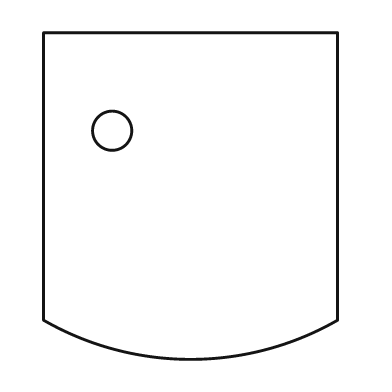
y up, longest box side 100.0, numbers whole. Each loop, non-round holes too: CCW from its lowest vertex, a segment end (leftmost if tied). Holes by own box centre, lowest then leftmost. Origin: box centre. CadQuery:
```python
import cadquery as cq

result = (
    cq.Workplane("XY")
    .moveTo(-45.0, -38.0)
    .threePointArc((0.0, -50.0), (45.0, -38.0))
    .lineTo(45.0, 50.0)
    .lineTo(-45.0, 50.0)
    .close()
    .moveTo(-24.0, 20.0)
    .circle(6.0)
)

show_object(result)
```